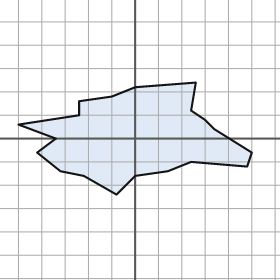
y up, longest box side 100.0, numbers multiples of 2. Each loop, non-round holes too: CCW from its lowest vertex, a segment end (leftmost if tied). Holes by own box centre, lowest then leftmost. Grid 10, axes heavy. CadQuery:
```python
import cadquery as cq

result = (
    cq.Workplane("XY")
    .moveTo(-8.0, -24.0)
    .lineTo(0.0, -16.0)
    .lineTo(14.0, -14.0)
    .lineTo(24.0, -10.0)
    .lineTo(48.0, -12.0)
    .lineTo(50.0, -6.0)
    .lineTo(34.0, 4.0)
    .lineTo(30.0, 8.0)
    .lineTo(24.0, 12.0)
    .lineTo(26.0, 24.0)
    .lineTo(0.0, 22.0)
    .lineTo(-10.0, 18.0)
    .lineTo(-24.0, 16.0)
    .lineTo(-24.0, 10.0)
    .lineTo(-50.0, 6.0)
    .lineTo(-34.0, 0.0)
    .lineTo(-42.0, -6.0)
    .lineTo(-32.0, -14.0)
    .lineTo(-22.0, -16.0)
    .close()
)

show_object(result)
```